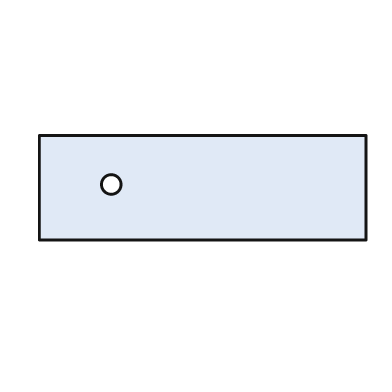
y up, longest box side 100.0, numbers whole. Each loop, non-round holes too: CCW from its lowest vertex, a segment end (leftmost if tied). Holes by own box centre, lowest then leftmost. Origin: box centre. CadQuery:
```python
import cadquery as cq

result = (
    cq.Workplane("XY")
    .moveTo(-50.0, -16.0)
    .lineTo(50.0, -16.0)
    .lineTo(50.0, 16.0)
    .lineTo(-50.0, 16.0)
    .close()
    .moveTo(-28.0, 1.0)
    .circle(3.0)
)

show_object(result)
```